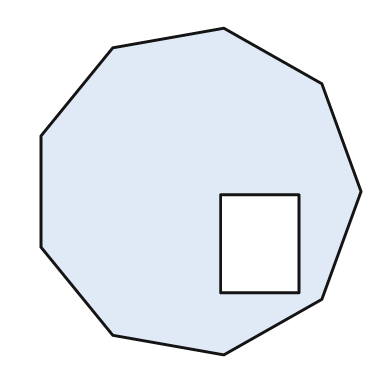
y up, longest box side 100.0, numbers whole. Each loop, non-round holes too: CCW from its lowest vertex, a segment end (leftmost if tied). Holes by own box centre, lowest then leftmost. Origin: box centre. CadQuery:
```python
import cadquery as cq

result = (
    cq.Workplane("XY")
    .moveTo(7.0, -50.0)
    .lineTo(37.0, -33.0)
    .lineTo(49.0, 0.0)
    .lineTo(37.0, 33.0)
    .lineTo(7.0, 50.0)
    .lineTo(-27.0, 44.0)
    .lineTo(-49.0, 17.0)
    .lineTo(-49.0, -17.0)
    .lineTo(-27.0, -44.0)
    .close()
    .moveTo(6.0, -31.0)
    .lineTo(30.0, -31.0)
    .lineTo(30.0, -1.0)
    .lineTo(6.0, -1.0)
    .close()
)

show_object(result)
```